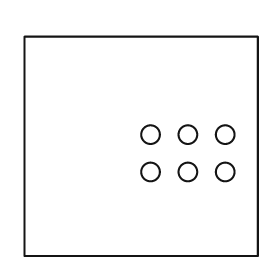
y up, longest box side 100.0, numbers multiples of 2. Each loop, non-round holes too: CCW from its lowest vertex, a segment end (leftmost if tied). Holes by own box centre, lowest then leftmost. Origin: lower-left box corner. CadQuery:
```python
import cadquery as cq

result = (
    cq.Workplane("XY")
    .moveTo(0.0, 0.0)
    .lineTo(100.0, 0.0)
    .lineTo(100.0, 94.0)
    .lineTo(0.0, 94.0)
    .close()
    .moveTo(54.0, 36.0)
    .circle(4.0)
    .moveTo(70.0, 36.0)
    .circle(4.0)
    .moveTo(86.0, 36.0)
    .circle(4.0)
    .moveTo(54.0, 52.0)
    .circle(4.0)
    .moveTo(70.0, 52.0)
    .circle(4.0)
    .moveTo(86.0, 52.0)
    .circle(4.0)
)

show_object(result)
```